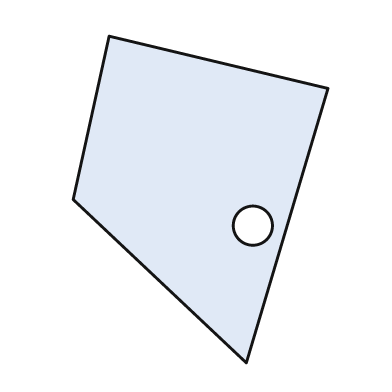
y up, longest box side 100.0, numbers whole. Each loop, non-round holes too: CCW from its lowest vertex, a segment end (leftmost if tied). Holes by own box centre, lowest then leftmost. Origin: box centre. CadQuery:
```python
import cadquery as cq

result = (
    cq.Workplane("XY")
    .moveTo(14.0, -50.0)
    .lineTo(39.0, 34.0)
    .lineTo(-28.0, 50.0)
    .lineTo(-39.0, 0.0)
    .close()
    .moveTo(16.0, -8.0)
    .circle(6.0)
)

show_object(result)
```